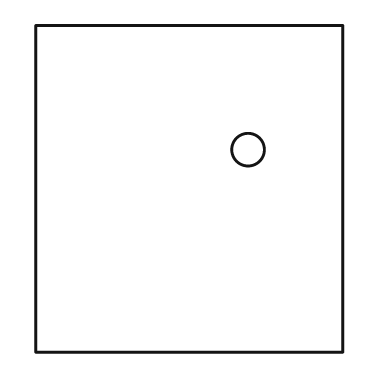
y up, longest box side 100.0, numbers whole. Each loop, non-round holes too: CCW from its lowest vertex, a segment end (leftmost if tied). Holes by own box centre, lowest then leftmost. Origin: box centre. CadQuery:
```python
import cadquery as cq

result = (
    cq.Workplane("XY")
    .moveTo(-47.0, -50.0)
    .lineTo(47.0, -50.0)
    .lineTo(47.0, 50.0)
    .lineTo(-47.0, 50.0)
    .close()
    .moveTo(18.0, 12.0)
    .circle(5.0)
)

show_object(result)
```